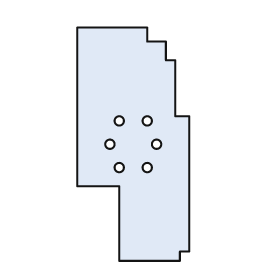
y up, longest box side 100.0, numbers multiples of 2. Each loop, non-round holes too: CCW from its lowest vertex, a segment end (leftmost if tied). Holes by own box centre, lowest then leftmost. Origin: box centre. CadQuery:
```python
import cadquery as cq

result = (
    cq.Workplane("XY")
    .moveTo(-6.0, -50.0)
    .lineTo(20.0, -50.0)
    .lineTo(20.0, -46.0)
    .lineTo(24.0, -46.0)
    .lineTo(24.0, 12.0)
    .lineTo(18.0, 12.0)
    .lineTo(18.0, 36.0)
    .lineTo(14.0, 36.0)
    .lineTo(14.0, 44.0)
    .lineTo(6.0, 44.0)
    .lineTo(6.0, 50.0)
    .lineTo(-24.0, 50.0)
    .lineTo(-24.0, -18.0)
    .lineTo(-6.0, -18.0)
    .close()
    .moveTo(-6.0, -10.0)
    .circle(2.0)
    .moveTo(6.0, -10.0)
    .circle(2.0)
    .moveTo(-10.0, 0.0)
    .circle(2.0)
    .moveTo(10.0, 0.0)
    .circle(2.0)
    .moveTo(-6.0, 10.0)
    .circle(2.0)
    .moveTo(6.0, 10.0)
    .circle(2.0)
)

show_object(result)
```